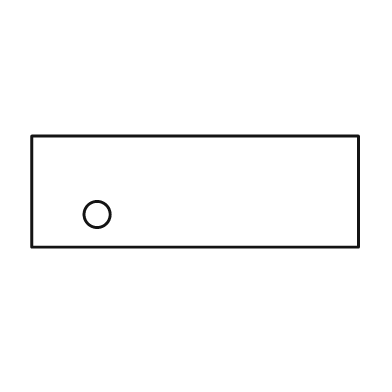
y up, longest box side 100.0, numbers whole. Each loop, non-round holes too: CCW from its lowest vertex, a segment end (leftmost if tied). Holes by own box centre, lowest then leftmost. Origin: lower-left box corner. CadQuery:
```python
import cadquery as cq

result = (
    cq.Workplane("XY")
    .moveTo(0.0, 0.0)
    .lineTo(100.0, 0.0)
    .lineTo(100.0, 34.0)
    .lineTo(0.0, 34.0)
    .close()
    .moveTo(20.0, 10.0)
    .circle(4.0)
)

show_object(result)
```